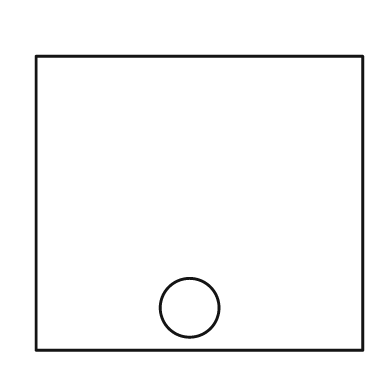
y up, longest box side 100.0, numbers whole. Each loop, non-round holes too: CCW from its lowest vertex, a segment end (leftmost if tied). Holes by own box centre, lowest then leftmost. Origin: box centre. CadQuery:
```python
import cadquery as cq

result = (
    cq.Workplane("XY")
    .moveTo(-50.0, -45.0)
    .lineTo(50.0, -45.0)
    .lineTo(50.0, 45.0)
    .lineTo(-50.0, 45.0)
    .close()
    .moveTo(-3.0, -32.0)
    .circle(9.0)
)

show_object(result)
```